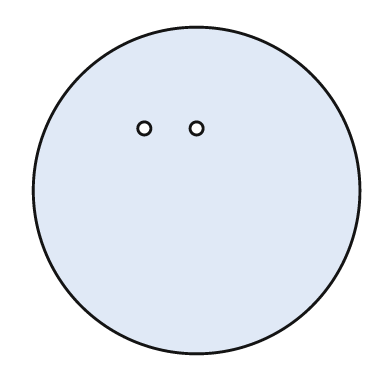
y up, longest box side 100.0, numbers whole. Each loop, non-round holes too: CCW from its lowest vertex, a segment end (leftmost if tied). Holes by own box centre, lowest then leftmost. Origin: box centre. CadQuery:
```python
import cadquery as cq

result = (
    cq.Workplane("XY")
    .moveTo(0.0, 0.0)
    .circle(50.0)
    .moveTo(-16.0, 19.0)
    .circle(2.0)
    .moveTo(0.0, 19.0)
    .circle(2.0)
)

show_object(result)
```